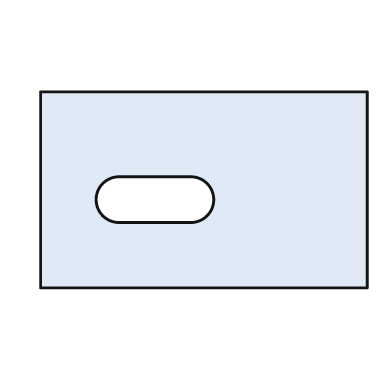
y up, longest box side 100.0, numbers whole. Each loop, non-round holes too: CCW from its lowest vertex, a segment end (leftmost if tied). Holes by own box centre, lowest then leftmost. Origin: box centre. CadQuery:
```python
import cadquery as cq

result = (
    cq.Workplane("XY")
    .moveTo(-50.0, -30.0)
    .lineTo(50.0, -30.0)
    .lineTo(50.0, 30.0)
    .lineTo(-50.0, 30.0)
    .close()
    .moveTo(-26.0, -10.0)
    .lineTo(-4.0, -10.0)
    .threePointArc((3.0, -3.0), (-4.0, 4.0))
    .lineTo(-26.0, 4.0)
    .threePointArc((-33.0, -3.0), (-26.0, -10.0))
    .close()
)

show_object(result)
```